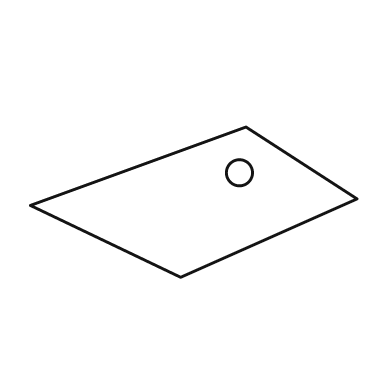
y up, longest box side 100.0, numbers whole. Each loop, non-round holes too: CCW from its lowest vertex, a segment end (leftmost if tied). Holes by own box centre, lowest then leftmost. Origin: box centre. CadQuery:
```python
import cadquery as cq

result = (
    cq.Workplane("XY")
    .moveTo(-4.0, -23.0)
    .lineTo(50.0, 1.0)
    .lineTo(16.0, 23.0)
    .lineTo(-50.0, -1.0)
    .close()
    .moveTo(14.0, 9.0)
    .circle(4.0)
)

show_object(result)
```